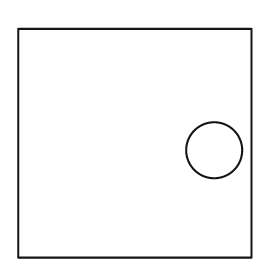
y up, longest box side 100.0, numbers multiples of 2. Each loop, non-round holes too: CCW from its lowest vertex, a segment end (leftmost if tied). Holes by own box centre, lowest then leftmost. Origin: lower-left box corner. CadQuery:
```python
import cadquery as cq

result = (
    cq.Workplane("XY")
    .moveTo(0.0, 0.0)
    .lineTo(100.0, 0.0)
    .lineTo(100.0, 98.0)
    .lineTo(0.0, 98.0)
    .close()
    .moveTo(84.0, 46.0)
    .circle(12.0)
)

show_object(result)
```